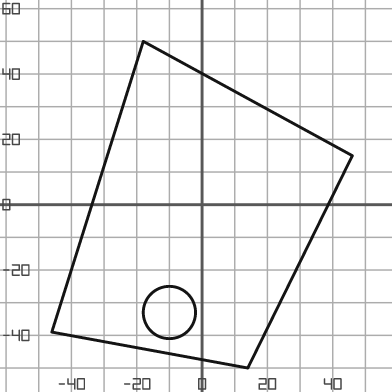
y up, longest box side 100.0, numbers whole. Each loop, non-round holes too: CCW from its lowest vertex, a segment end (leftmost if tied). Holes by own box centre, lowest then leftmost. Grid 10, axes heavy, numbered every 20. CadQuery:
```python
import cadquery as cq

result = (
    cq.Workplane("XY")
    .moveTo(14.0, -50.0)
    .lineTo(46.0, 15.0)
    .lineTo(-18.0, 50.0)
    .lineTo(-46.0, -39.0)
    .close()
    .moveTo(-10.0, -33.0)
    .circle(8.0)
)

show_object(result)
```